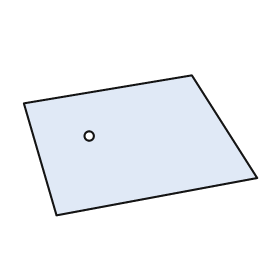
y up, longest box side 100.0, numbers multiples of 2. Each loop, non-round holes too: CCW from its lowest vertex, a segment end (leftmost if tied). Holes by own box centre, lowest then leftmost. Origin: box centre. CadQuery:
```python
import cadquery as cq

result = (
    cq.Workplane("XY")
    .moveTo(-36.0, -30.0)
    .lineTo(50.0, -14.0)
    .lineTo(22.0, 30.0)
    .lineTo(-50.0, 18.0)
    .close()
    .moveTo(-22.0, 4.0)
    .circle(2.0)
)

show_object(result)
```